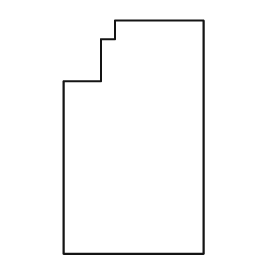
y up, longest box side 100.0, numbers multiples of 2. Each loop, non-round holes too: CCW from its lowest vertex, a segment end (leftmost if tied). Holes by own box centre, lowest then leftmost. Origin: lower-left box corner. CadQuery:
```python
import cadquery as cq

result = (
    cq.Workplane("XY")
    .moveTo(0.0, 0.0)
    .lineTo(60.0, 0.0)
    .lineTo(60.0, 100.0)
    .lineTo(22.0, 100.0)
    .lineTo(22.0, 92.0)
    .lineTo(16.0, 92.0)
    .lineTo(16.0, 74.0)
    .lineTo(0.0, 74.0)
    .close()
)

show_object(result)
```